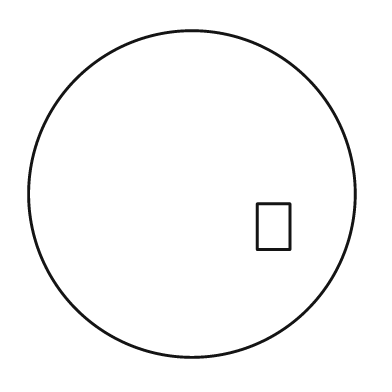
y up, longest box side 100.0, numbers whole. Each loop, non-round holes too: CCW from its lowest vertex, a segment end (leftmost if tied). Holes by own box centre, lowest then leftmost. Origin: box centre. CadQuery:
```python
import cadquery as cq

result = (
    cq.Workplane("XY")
    .moveTo(0.0, 0.0)
    .circle(50.0)
    .moveTo(20.0, -17.0)
    .lineTo(30.0, -17.0)
    .lineTo(30.0, -3.0)
    .lineTo(20.0, -3.0)
    .close()
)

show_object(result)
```